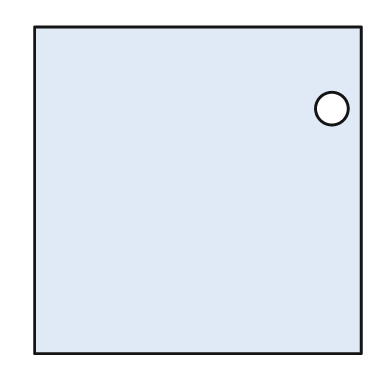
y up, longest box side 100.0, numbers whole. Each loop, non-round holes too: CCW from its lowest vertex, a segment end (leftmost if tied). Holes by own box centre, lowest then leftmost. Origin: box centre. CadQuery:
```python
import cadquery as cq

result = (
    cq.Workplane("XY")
    .moveTo(-50.0, -50.0)
    .lineTo(50.0, -50.0)
    .lineTo(50.0, 50.0)
    .lineTo(-50.0, 50.0)
    .close()
    .moveTo(41.0, 25.0)
    .circle(5.0)
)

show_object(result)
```